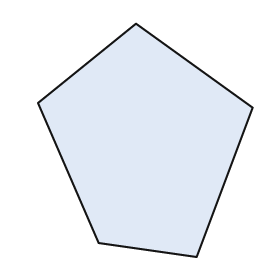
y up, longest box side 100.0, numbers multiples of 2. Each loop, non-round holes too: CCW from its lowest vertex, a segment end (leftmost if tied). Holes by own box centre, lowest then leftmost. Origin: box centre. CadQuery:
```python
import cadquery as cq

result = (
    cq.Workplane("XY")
    .moveTo(22.0, -50.0)
    .lineTo(46.0, 14.0)
    .lineTo(-4.0, 50.0)
    .lineTo(-46.0, 16.0)
    .lineTo(-20.0, -44.0)
    .close()
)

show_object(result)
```